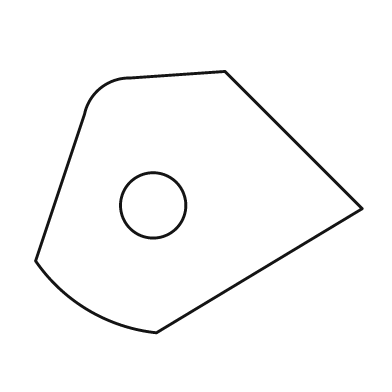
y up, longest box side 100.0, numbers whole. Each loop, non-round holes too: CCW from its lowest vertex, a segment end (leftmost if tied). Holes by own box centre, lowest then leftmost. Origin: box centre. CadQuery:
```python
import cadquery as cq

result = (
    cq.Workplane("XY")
    .moveTo(-13.0, -40.0)
    .lineTo(50.0, -2.0)
    .lineTo(8.0, 40.0)
    .lineTo(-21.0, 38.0)
    .threePointArc((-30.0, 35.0), (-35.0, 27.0))
    .lineTo(-50.0, -18.0)
    .threePointArc((-34.0, -33.0), (-13.0, -40.0))
    .close()
    .moveTo(-14.0, -1.0)
    .circle(10.0)
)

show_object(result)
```